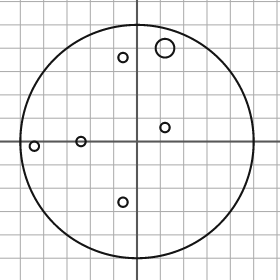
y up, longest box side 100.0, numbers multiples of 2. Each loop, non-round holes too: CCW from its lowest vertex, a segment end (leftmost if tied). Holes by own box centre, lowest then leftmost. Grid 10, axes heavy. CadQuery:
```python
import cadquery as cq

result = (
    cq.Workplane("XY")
    .moveTo(0.0, 0.0)
    .circle(50.0)
    .moveTo(-6.0, -26.0)
    .circle(2.0)
    .moveTo(-44.0, -2.0)
    .circle(2.0)
    .moveTo(-24.0, 0.0)
    .circle(2.0)
    .moveTo(12.0, 6.0)
    .circle(2.0)
    .moveTo(-6.0, 36.0)
    .circle(2.0)
    .moveTo(12.0, 40.0)
    .circle(4.0)
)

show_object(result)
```